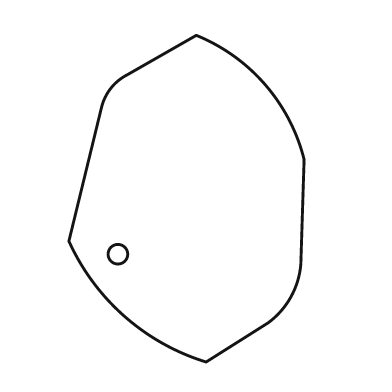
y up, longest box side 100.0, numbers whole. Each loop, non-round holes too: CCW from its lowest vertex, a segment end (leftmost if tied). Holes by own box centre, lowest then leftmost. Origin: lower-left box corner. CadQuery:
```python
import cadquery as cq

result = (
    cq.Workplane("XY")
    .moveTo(42.0, 0.0)
    .lineTo(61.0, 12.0)
    .threePointArc((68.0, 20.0), (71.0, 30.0))
    .lineTo(72.0, 62.0)
    .threePointArc((60.0, 85.0), (39.0, 100.0))
    .lineTo(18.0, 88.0)
    .threePointArc((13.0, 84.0), (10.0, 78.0))
    .lineTo(0.0, 37.0)
    .threePointArc((17.0, 14.0), (42.0, 0.0))
    .close()
    .moveTo(15.0, 33.0)
    .circle(3.0)
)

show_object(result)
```